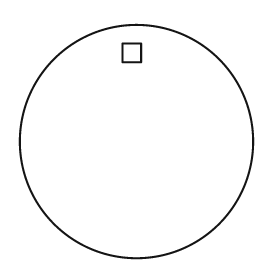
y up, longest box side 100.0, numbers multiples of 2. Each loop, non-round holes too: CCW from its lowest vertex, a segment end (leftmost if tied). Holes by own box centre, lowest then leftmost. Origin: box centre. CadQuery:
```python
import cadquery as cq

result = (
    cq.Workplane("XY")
    .moveTo(0.0, 0.0)
    .circle(50.0)
    .moveTo(-6.0, 34.0)
    .lineTo(2.0, 34.0)
    .lineTo(2.0, 42.0)
    .lineTo(-6.0, 42.0)
    .close()
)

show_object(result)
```